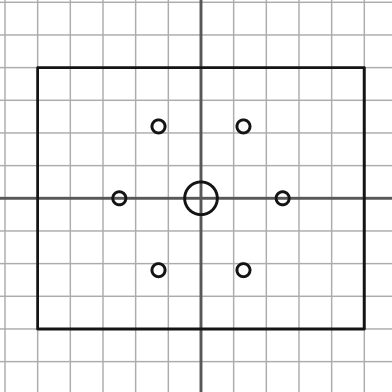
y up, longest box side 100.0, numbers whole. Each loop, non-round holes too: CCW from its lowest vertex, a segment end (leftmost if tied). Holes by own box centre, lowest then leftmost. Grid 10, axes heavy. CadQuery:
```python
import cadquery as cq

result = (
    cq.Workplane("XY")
    .moveTo(-50.0, -40.0)
    .lineTo(50.0, -40.0)
    .lineTo(50.0, 40.0)
    .lineTo(-50.0, 40.0)
    .close()
    .moveTo(-13.0, -22.0)
    .circle(2.0)
    .moveTo(13.0, -22.0)
    .circle(2.0)
    .moveTo(-25.0, 0.0)
    .circle(2.0)
    .moveTo(0.0, 0.0)
    .circle(5.0)
    .moveTo(25.0, 0.0)
    .circle(2.0)
    .moveTo(-13.0, 22.0)
    .circle(2.0)
    .moveTo(13.0, 22.0)
    .circle(2.0)
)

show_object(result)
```